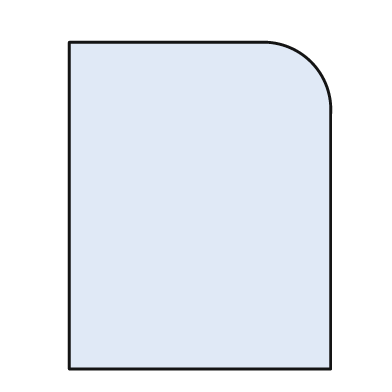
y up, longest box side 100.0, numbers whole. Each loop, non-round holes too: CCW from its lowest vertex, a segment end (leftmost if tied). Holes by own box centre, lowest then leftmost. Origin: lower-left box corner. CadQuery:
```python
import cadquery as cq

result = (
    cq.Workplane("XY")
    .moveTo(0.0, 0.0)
    .lineTo(80.0, 0.0)
    .lineTo(80.0, 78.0)
    .threePointArc((74.0, 94.0), (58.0, 100.0))
    .lineTo(0.0, 100.0)
    .close()
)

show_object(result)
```